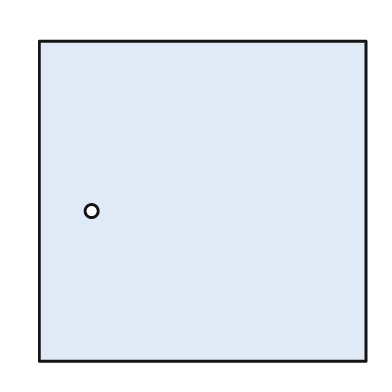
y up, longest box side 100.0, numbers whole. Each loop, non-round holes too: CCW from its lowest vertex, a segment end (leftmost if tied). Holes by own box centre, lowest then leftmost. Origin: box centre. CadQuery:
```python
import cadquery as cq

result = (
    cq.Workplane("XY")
    .moveTo(-50.0, -49.0)
    .lineTo(50.0, -49.0)
    .lineTo(50.0, 49.0)
    .lineTo(-50.0, 49.0)
    .close()
    .moveTo(-34.0, -3.0)
    .circle(2.0)
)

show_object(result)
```